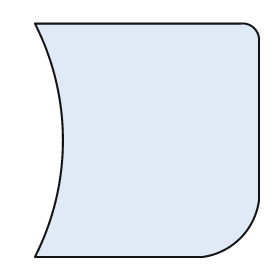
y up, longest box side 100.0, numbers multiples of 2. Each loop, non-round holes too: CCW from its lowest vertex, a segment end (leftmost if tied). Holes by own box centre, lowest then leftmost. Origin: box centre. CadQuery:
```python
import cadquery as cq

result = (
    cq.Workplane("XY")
    .moveTo(-48.0, -50.0)
    .lineTo(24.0, -50.0)
    .threePointArc((40.0, -42.0), (48.0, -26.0))
    .lineTo(48.0, 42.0)
    .threePointArc((46.0, 48.0), (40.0, 50.0))
    .lineTo(-48.0, 50.0)
    .threePointArc((-36.0, 0.0), (-48.0, -50.0))
    .close()
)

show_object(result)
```